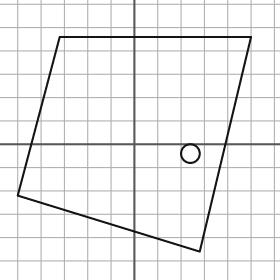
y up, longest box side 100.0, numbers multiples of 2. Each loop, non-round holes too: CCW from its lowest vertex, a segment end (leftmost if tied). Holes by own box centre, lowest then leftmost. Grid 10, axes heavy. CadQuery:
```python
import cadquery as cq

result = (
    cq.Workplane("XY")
    .moveTo(28.0, -46.0)
    .lineTo(50.0, 46.0)
    .lineTo(-32.0, 46.0)
    .lineTo(-50.0, -22.0)
    .close()
    .moveTo(24.0, -4.0)
    .circle(4.0)
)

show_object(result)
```